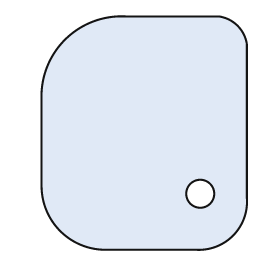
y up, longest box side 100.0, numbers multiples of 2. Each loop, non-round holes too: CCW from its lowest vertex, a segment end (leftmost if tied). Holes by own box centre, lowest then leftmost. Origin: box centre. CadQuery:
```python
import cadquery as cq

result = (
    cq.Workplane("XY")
    .moveTo(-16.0, -50.0)
    .lineTo(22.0, -50.0)
    .threePointArc((38.0, -44.0), (44.0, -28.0))
    .lineTo(44.0, 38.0)
    .threePointArc((40.0, 46.0), (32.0, 50.0))
    .lineTo(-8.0, 50.0)
    .threePointArc((-34.0, 40.0), (-44.0, 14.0))
    .lineTo(-44.0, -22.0)
    .threePointArc((-36.0, -42.0), (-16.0, -50.0))
    .close()
    .moveTo(24.0, -26.0)
    .circle(6.0)
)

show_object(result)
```